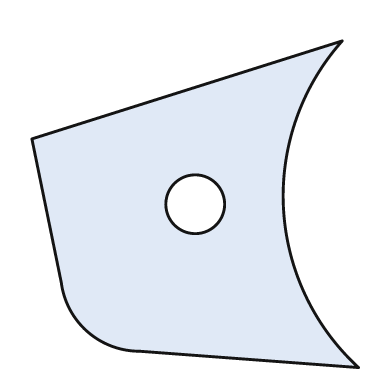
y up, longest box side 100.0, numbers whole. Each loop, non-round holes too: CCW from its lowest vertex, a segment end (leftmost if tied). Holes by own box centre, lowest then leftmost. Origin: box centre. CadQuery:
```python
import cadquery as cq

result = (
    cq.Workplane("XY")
    .moveTo(50.0, -50.0)
    .threePointArc((27.0, -1.0), (45.0, 50.0))
    .lineTo(-50.0, 20.0)
    .lineTo(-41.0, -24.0)
    .threePointArc((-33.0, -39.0), (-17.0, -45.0))
    .close()
    .moveTo(0.0, 0.0)
    .circle(9.0)
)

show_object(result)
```